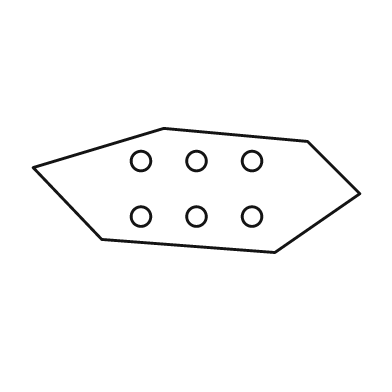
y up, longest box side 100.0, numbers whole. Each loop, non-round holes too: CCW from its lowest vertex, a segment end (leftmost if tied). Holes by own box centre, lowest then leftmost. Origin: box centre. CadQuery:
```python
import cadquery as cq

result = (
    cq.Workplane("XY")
    .moveTo(24.0, -19.0)
    .lineTo(50.0, -1.0)
    .lineTo(34.0, 15.0)
    .lineTo(-10.0, 19.0)
    .lineTo(-50.0, 7.0)
    .lineTo(-29.0, -15.0)
    .close()
    .moveTo(-17.0, -8.0)
    .circle(3.0)
    .moveTo(0.0, -8.0)
    .circle(3.0)
    .moveTo(17.0, -8.0)
    .circle(3.0)
    .moveTo(-17.0, 9.0)
    .circle(3.0)
    .moveTo(0.0, 9.0)
    .circle(3.0)
    .moveTo(17.0, 9.0)
    .circle(3.0)
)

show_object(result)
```